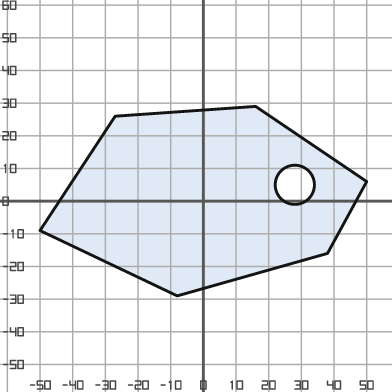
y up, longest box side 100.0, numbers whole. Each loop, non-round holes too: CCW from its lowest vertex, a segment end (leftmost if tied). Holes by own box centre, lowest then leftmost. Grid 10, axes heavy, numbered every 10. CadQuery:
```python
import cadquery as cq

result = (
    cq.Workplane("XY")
    .moveTo(-8.0, -29.0)
    .lineTo(38.0, -16.0)
    .lineTo(50.0, 6.0)
    .lineTo(16.0, 29.0)
    .lineTo(-27.0, 26.0)
    .lineTo(-50.0, -9.0)
    .close()
    .moveTo(28.0, 5.0)
    .circle(6.0)
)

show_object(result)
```